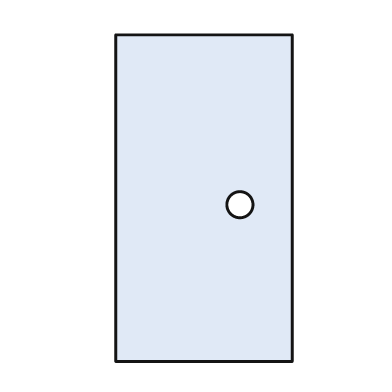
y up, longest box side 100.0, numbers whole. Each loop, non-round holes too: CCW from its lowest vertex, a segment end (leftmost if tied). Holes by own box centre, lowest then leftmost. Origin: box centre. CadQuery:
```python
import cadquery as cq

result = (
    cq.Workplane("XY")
    .moveTo(-27.0, -50.0)
    .lineTo(27.0, -50.0)
    .lineTo(27.0, 50.0)
    .lineTo(-27.0, 50.0)
    .close()
    .moveTo(11.0, -2.0)
    .circle(4.0)
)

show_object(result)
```